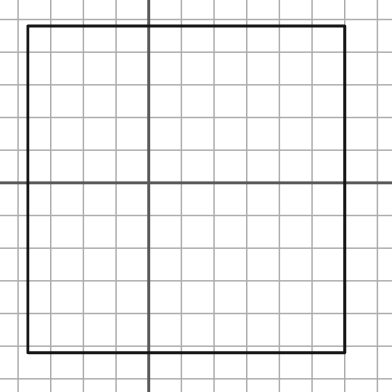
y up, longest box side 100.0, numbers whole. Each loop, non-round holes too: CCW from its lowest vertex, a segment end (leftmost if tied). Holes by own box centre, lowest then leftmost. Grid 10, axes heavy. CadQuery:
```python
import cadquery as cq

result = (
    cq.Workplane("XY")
    .moveTo(-37.0, -52.0)
    .lineTo(60.0, -52.0)
    .lineTo(60.0, 48.0)
    .lineTo(-37.0, 48.0)
    .close()
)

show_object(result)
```